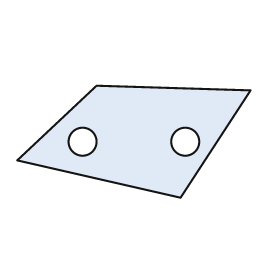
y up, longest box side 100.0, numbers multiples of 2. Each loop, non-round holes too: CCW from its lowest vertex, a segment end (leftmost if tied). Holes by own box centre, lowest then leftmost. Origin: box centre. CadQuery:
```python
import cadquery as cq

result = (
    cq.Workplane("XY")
    .moveTo(20.0, -24.0)
    .lineTo(50.0, 22.0)
    .lineTo(-16.0, 24.0)
    .lineTo(-50.0, -8.0)
    .close()
    .moveTo(-22.0, 0.0)
    .circle(6.0)
    .moveTo(22.0, 0.0)
    .circle(6.0)
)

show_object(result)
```